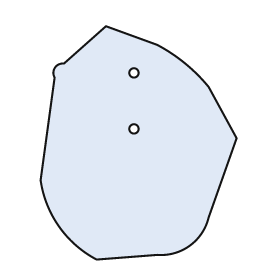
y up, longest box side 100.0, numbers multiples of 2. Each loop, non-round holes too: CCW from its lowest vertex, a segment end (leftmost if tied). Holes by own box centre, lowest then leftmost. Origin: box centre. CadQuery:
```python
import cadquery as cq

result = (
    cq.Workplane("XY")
    .moveTo(-18.0, -50.0)
    .lineTo(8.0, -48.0)
    .threePointArc((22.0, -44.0), (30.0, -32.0))
    .lineTo(42.0, 2.0)
    .lineTo(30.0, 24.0)
    .threePointArc((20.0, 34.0), (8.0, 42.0))
    .lineTo(-14.0, 50.0)
    .lineTo(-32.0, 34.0)
    .threePointArc((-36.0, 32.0), (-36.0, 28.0))
    .lineTo(-42.0, -16.0)
    .threePointArc((-34.0, -36.0), (-18.0, -50.0))
    .close()
    .moveTo(-2.0, 6.0)
    .circle(2.0)
    .moveTo(-2.0, 30.0)
    .circle(2.0)
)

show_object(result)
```